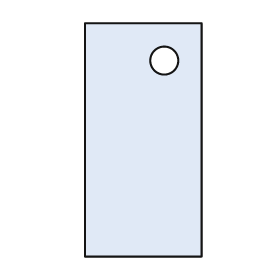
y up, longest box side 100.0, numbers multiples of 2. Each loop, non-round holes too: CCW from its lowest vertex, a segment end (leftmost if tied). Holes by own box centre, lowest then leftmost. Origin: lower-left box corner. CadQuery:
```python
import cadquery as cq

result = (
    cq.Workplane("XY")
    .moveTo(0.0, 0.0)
    .lineTo(50.0, 0.0)
    .lineTo(50.0, 100.0)
    .lineTo(0.0, 100.0)
    .close()
    .moveTo(34.0, 84.0)
    .circle(6.0)
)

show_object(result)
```